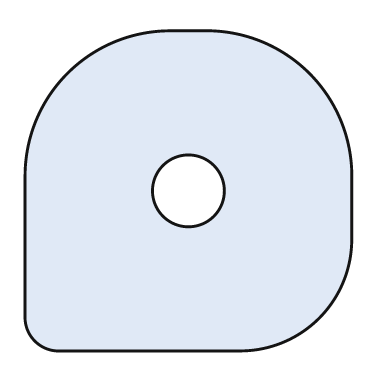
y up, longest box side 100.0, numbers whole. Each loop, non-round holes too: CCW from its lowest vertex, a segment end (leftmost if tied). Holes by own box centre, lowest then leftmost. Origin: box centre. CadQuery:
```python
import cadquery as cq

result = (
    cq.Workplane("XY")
    .moveTo(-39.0, -49.0)
    .lineTo(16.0, -49.0)
    .threePointArc((40.0, -39.0), (50.0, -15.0))
    .lineTo(50.0, 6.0)
    .threePointArc((37.0, 36.0), (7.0, 49.0))
    .lineTo(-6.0, 49.0)
    .threePointArc((-37.0, 36.0), (-50.0, 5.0))
    .lineTo(-50.0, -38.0)
    .threePointArc((-47.0, -46.0), (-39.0, -49.0))
    .close()
    .moveTo(0.0, 0.0)
    .circle(11.0)
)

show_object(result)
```